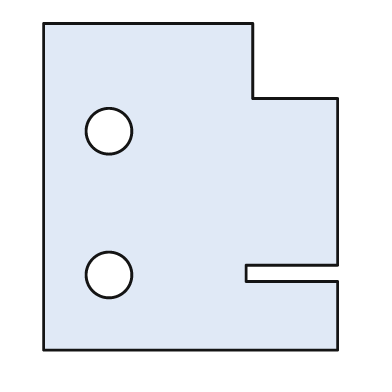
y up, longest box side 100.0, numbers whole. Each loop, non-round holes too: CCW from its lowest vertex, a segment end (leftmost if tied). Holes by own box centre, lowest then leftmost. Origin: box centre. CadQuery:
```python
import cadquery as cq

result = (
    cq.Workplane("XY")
    .moveTo(-45.0, -50.0)
    .lineTo(45.0, -50.0)
    .lineTo(45.0, -29.0)
    .lineTo(17.0, -29.0)
    .lineTo(17.0, -24.0)
    .lineTo(45.0, -24.0)
    .lineTo(45.0, 27.0)
    .lineTo(19.0, 27.0)
    .lineTo(19.0, 50.0)
    .lineTo(-45.0, 50.0)
    .close()
    .moveTo(-25.0, -27.0)
    .circle(7.0)
    .moveTo(-25.0, 17.0)
    .circle(7.0)
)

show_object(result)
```